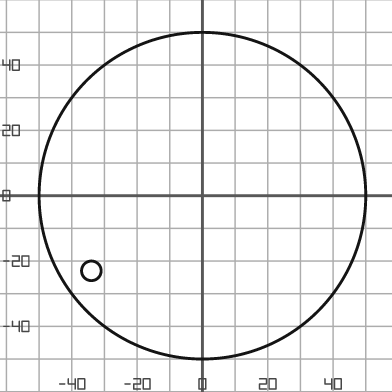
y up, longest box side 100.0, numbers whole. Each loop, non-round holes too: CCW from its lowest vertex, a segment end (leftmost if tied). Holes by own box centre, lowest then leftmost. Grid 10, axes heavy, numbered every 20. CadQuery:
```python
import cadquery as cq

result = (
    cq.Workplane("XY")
    .moveTo(0.0, 0.0)
    .circle(50.0)
    .moveTo(-34.0, -23.0)
    .circle(3.0)
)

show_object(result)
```